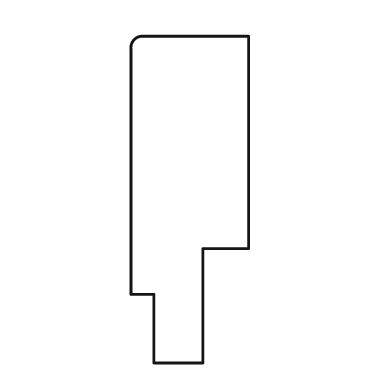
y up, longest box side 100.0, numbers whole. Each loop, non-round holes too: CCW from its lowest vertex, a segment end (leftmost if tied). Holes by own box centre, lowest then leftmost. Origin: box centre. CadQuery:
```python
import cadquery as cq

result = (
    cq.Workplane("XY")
    .moveTo(-11.0, -50.0)
    .lineTo(4.0, -50.0)
    .lineTo(4.0, -15.0)
    .lineTo(18.0, -15.0)
    .lineTo(18.0, 50.0)
    .lineTo(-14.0, 50.0)
    .threePointArc((-17.0, 49.0), (-18.0, 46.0))
    .lineTo(-18.0, -29.0)
    .lineTo(-11.0, -29.0)
    .close()
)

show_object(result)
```